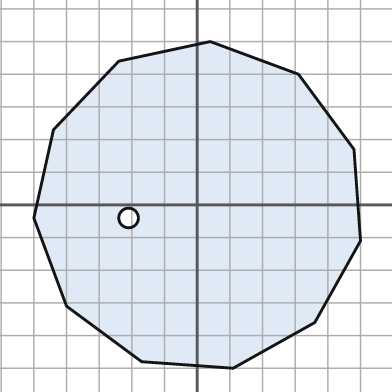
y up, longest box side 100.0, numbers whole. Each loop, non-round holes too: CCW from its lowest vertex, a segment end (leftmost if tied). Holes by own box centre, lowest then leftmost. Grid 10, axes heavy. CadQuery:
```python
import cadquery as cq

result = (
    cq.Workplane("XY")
    .moveTo(11.0, -50.0)
    .lineTo(36.0, -36.0)
    .lineTo(50.0, -11.0)
    .lineTo(48.0, 17.0)
    .lineTo(31.0, 40.0)
    .lineTo(4.0, 50.0)
    .lineTo(-24.0, 44.0)
    .lineTo(-44.0, 23.0)
    .lineTo(-50.0, -4.0)
    .lineTo(-40.0, -31.0)
    .lineTo(-17.0, -48.0)
    .close()
    .moveTo(-21.0, -4.0)
    .circle(3.0)
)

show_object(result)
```